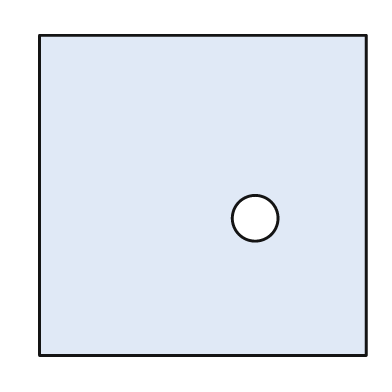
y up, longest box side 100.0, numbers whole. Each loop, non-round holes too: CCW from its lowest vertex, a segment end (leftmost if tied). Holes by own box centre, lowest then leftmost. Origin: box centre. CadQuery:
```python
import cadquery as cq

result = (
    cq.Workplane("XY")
    .moveTo(-50.0, -49.0)
    .lineTo(50.0, -49.0)
    .lineTo(50.0, 49.0)
    .lineTo(-50.0, 49.0)
    .close()
    .moveTo(16.0, -7.0)
    .circle(7.0)
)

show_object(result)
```